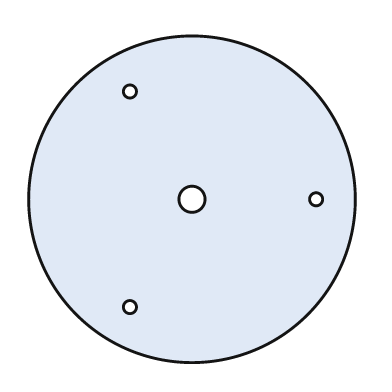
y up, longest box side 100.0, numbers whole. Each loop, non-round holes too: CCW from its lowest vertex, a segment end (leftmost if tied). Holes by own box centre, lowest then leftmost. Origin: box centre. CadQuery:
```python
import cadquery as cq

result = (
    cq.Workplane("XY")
    .moveTo(0.0, 0.0)
    .circle(50.0)
    .moveTo(-19.0, -33.0)
    .circle(2.0)
    .moveTo(0.0, 0.0)
    .circle(4.0)
    .moveTo(38.0, 0.0)
    .circle(2.0)
    .moveTo(-19.0, 33.0)
    .circle(2.0)
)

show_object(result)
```